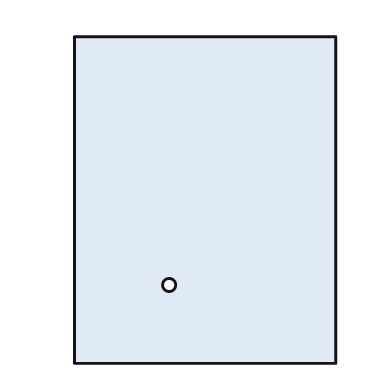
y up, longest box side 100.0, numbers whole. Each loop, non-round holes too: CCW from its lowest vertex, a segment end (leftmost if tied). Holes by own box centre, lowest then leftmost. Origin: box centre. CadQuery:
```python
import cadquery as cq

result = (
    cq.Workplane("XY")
    .moveTo(-40.0, -50.0)
    .lineTo(40.0, -50.0)
    .lineTo(40.0, 50.0)
    .lineTo(-40.0, 50.0)
    .close()
    .moveTo(-11.0, -26.0)
    .circle(2.0)
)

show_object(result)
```